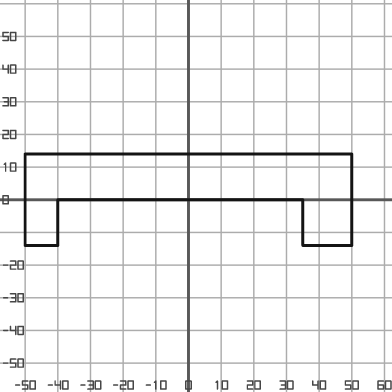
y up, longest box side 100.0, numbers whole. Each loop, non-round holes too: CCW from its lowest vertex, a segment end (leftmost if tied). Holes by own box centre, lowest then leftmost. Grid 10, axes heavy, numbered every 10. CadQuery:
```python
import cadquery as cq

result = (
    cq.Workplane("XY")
    .moveTo(-50.0, -14.0)
    .lineTo(-40.0, -14.0)
    .lineTo(-40.0, 0.0)
    .lineTo(35.0, 0.0)
    .lineTo(35.0, -14.0)
    .lineTo(50.0, -14.0)
    .lineTo(50.0, 14.0)
    .lineTo(-50.0, 14.0)
    .close()
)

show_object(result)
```